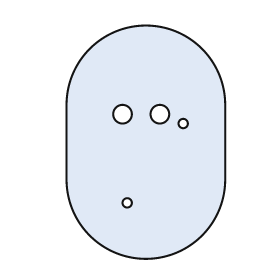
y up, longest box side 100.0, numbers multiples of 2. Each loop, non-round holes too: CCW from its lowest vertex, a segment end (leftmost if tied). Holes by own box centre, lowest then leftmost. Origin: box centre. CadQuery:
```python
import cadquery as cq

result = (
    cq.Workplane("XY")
    .moveTo(-34.0, -16.0)
    .threePointArc((0.0, -50.0), (34.0, -16.0))
    .lineTo(34.0, 16.0)
    .threePointArc((0.0, 50.0), (-34.0, 16.0))
    .close()
    .moveTo(-8.0, -26.0)
    .circle(2.0)
    .moveTo(16.0, 8.0)
    .circle(2.0)
    .moveTo(-10.0, 12.0)
    .circle(4.0)
    .moveTo(6.0, 12.0)
    .circle(4.0)
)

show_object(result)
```